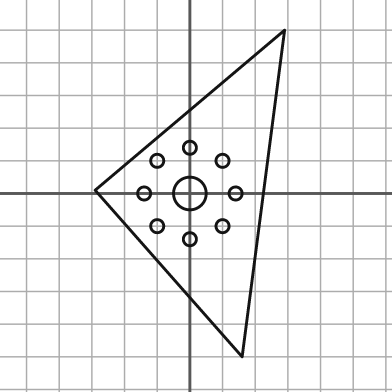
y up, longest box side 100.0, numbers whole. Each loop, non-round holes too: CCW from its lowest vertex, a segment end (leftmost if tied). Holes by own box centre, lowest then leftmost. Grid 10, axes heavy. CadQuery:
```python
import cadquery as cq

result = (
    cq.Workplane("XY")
    .moveTo(16.0, -50.0)
    .lineTo(29.0, 50.0)
    .lineTo(-29.0, 1.0)
    .close()
    .moveTo(0.0, -14.0)
    .circle(2.0)
    .moveTo(-10.0, -10.0)
    .circle(2.0)
    .moveTo(10.0, -10.0)
    .circle(2.0)
    .moveTo(-14.0, 0.0)
    .circle(2.0)
    .moveTo(0.0, 0.0)
    .circle(5.0)
    .moveTo(14.0, 0.0)
    .circle(2.0)
    .moveTo(-10.0, 10.0)
    .circle(2.0)
    .moveTo(10.0, 10.0)
    .circle(2.0)
    .moveTo(0.0, 14.0)
    .circle(2.0)
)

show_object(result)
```